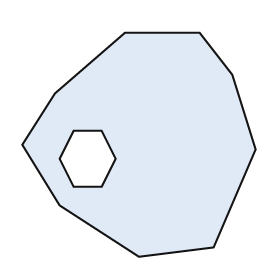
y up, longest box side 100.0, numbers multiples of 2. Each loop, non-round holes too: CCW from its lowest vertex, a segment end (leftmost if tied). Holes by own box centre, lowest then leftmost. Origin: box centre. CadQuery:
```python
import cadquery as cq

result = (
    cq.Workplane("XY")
    .moveTo(0.0, -48.0)
    .lineTo(32.0, -44.0)
    .lineTo(50.0, -2.0)
    .lineTo(40.0, 30.0)
    .lineTo(26.0, 48.0)
    .lineTo(-6.0, 48.0)
    .lineTo(-36.0, 22.0)
    .lineTo(-50.0, 0.0)
    .lineTo(-34.0, -26.0)
    .close()
    .moveTo(-28.0, -18.0)
    .lineTo(-16.0, -18.0)
    .lineTo(-10.0, -6.0)
    .lineTo(-16.0, 6.0)
    .lineTo(-28.0, 6.0)
    .lineTo(-34.0, -6.0)
    .close()
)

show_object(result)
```